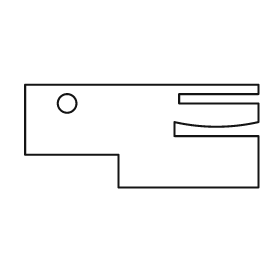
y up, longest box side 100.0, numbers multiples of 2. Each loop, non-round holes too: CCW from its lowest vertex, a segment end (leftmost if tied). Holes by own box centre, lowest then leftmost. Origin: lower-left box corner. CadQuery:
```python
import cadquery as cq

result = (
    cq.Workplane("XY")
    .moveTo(40.0, 0.0)
    .lineTo(100.0, 0.0)
    .lineTo(100.0, 22.0)
    .lineTo(64.0, 22.0)
    .lineTo(64.0, 28.0)
    .threePointArc((82.0, 26.0), (100.0, 28.0))
    .lineTo(100.0, 36.0)
    .lineTo(66.0, 36.0)
    .lineTo(66.0, 40.0)
    .lineTo(100.0, 40.0)
    .lineTo(100.0, 44.0)
    .lineTo(0.0, 44.0)
    .lineTo(0.0, 14.0)
    .lineTo(40.0, 14.0)
    .close()
    .moveTo(18.0, 36.0)
    .circle(4.0)
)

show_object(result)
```